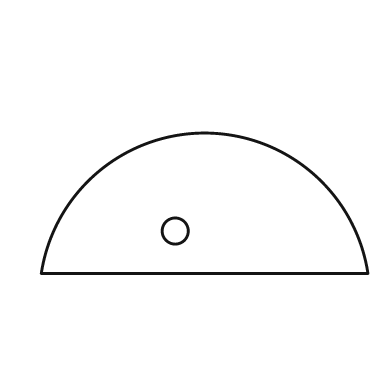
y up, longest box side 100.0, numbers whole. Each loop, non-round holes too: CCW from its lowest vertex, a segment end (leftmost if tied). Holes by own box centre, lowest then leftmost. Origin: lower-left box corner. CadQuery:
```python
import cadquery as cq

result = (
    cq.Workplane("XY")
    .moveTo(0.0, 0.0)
    .lineTo(100.0, 0.0)
    .threePointArc((50.0, 43.0), (0.0, 0.0))
    .close()
    .moveTo(41.0, 13.0)
    .circle(4.0)
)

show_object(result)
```